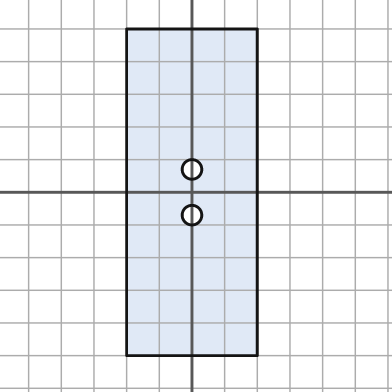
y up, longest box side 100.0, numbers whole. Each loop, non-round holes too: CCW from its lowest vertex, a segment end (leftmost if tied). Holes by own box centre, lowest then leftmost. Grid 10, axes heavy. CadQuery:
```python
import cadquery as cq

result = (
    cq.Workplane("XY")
    .moveTo(-20.0, -50.0)
    .lineTo(20.0, -50.0)
    .lineTo(20.0, 50.0)
    .lineTo(-20.0, 50.0)
    .close()
    .moveTo(0.0, -7.0)
    .circle(3.0)
    .moveTo(0.0, 7.0)
    .circle(3.0)
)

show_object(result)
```